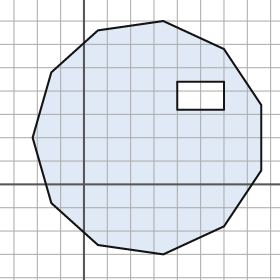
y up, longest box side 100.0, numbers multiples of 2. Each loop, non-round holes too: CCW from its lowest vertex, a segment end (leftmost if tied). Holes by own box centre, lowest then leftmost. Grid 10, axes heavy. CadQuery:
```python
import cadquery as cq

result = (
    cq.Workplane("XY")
    .moveTo(34.0, -30.0)
    .lineTo(60.0, -18.0)
    .lineTo(76.0, 6.0)
    .lineTo(76.0, 34.0)
    .lineTo(60.0, 58.0)
    .lineTo(34.0, 70.0)
    .lineTo(6.0, 66.0)
    .lineTo(-14.0, 48.0)
    .lineTo(-22.0, 20.0)
    .lineTo(-14.0, -8.0)
    .lineTo(6.0, -26.0)
    .close()
    .moveTo(40.0, 32.0)
    .lineTo(60.0, 32.0)
    .lineTo(60.0, 44.0)
    .lineTo(40.0, 44.0)
    .close()
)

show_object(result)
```